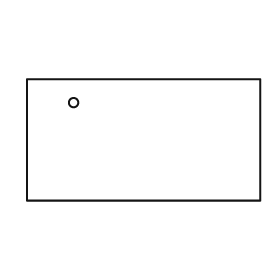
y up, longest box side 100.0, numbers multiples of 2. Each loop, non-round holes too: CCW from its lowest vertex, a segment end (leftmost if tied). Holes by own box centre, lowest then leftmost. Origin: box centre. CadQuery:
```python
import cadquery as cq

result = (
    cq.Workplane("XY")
    .moveTo(-50.0, -26.0)
    .lineTo(50.0, -26.0)
    .lineTo(50.0, 26.0)
    .lineTo(-50.0, 26.0)
    .close()
    .moveTo(-30.0, 16.0)
    .circle(2.0)
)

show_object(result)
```